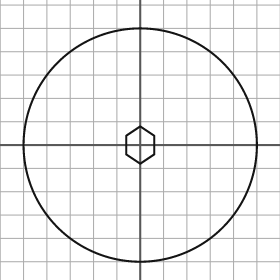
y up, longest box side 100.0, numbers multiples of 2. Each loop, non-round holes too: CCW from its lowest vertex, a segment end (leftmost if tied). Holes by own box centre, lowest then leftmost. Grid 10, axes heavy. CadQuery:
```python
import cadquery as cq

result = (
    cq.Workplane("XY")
    .moveTo(0.0, 0.0)
    .circle(50.0)
    .moveTo(0.0, -8.0)
    .lineTo(6.0, -4.0)
    .lineTo(6.0, 4.0)
    .lineTo(0.0, 8.0)
    .lineTo(-6.0, 4.0)
    .lineTo(-6.0, -4.0)
    .close()
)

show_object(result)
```